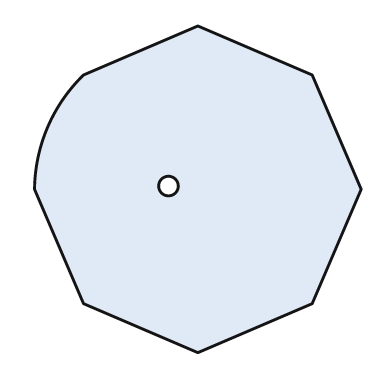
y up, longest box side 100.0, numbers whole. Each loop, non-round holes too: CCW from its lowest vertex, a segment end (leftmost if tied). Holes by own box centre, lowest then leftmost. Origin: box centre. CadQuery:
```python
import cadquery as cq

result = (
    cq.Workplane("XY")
    .moveTo(0.0, -50.0)
    .lineTo(35.0, -35.0)
    .lineTo(50.0, 0.0)
    .lineTo(35.0, 35.0)
    .lineTo(0.0, 50.0)
    .lineTo(-35.0, 35.0)
    .threePointArc((-46.0, 19.0), (-50.0, 0.0))
    .lineTo(-35.0, -35.0)
    .close()
    .moveTo(-9.0, 1.0)
    .circle(3.0)
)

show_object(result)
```